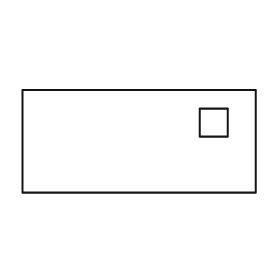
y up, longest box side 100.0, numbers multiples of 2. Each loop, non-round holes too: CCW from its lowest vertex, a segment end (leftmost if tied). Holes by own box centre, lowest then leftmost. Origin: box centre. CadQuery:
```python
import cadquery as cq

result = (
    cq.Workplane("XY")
    .moveTo(-50.0, -22.0)
    .lineTo(50.0, -22.0)
    .lineTo(50.0, 22.0)
    .lineTo(-50.0, 22.0)
    .close()
    .moveTo(26.0, 2.0)
    .lineTo(38.0, 2.0)
    .lineTo(38.0, 14.0)
    .lineTo(26.0, 14.0)
    .close()
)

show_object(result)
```